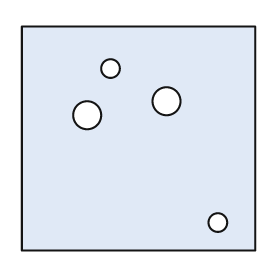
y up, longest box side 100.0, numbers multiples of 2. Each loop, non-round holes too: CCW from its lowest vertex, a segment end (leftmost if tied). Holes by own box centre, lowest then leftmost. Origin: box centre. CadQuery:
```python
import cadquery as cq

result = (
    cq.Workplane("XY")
    .moveTo(-50.0, -48.0)
    .lineTo(50.0, -48.0)
    .lineTo(50.0, 48.0)
    .lineTo(-50.0, 48.0)
    .close()
    .moveTo(34.0, -36.0)
    .circle(4.0)
    .moveTo(-22.0, 10.0)
    .circle(6.0)
    .moveTo(12.0, 16.0)
    .circle(6.0)
    .moveTo(-12.0, 30.0)
    .circle(4.0)
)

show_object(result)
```